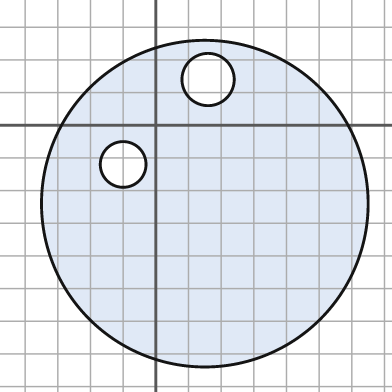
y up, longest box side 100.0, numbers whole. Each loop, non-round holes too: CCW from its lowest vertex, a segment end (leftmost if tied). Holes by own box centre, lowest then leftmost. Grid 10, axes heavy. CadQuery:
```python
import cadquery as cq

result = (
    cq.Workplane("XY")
    .moveTo(15.0, -24.0)
    .circle(50.0)
    .moveTo(-10.0, -12.0)
    .circle(7.0)
    .moveTo(16.0, 14.0)
    .circle(8.0)
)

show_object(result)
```